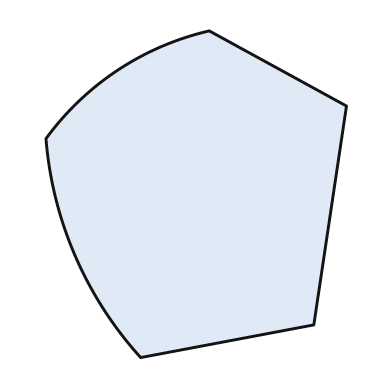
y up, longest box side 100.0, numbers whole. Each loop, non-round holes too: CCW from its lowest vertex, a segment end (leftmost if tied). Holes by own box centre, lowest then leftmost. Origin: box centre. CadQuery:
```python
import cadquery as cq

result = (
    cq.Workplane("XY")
    .moveTo(-17.0, -50.0)
    .lineTo(36.0, -40.0)
    .lineTo(46.0, 27.0)
    .lineTo(4.0, 50.0)
    .threePointArc((-24.0, 38.0), (-46.0, 17.0))
    .threePointArc((-37.0, -19.0), (-17.0, -50.0))
    .close()
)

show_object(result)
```